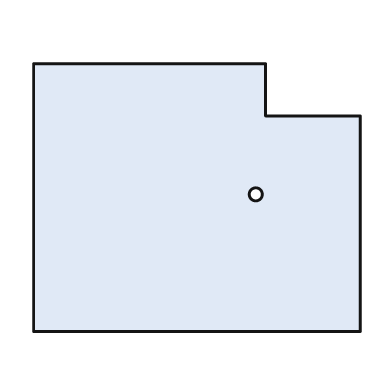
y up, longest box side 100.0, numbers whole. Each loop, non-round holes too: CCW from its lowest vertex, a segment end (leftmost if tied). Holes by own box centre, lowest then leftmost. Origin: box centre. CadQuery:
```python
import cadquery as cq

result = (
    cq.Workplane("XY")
    .moveTo(-50.0, -41.0)
    .lineTo(50.0, -41.0)
    .lineTo(50.0, 25.0)
    .lineTo(21.0, 25.0)
    .lineTo(21.0, 41.0)
    .lineTo(-50.0, 41.0)
    .close()
    .moveTo(18.0, 1.0)
    .circle(2.0)
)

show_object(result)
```